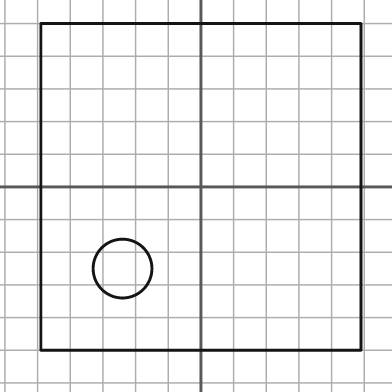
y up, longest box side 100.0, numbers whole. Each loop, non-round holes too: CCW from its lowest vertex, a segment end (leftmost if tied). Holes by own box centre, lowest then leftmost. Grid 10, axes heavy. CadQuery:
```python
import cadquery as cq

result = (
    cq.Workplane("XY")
    .moveTo(-49.0, -50.0)
    .lineTo(49.0, -50.0)
    .lineTo(49.0, 50.0)
    .lineTo(-49.0, 50.0)
    .close()
    .moveTo(-24.0, -25.0)
    .circle(9.0)
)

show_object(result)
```